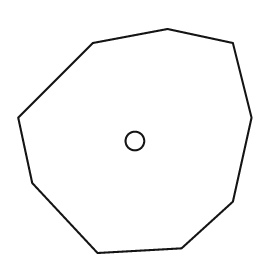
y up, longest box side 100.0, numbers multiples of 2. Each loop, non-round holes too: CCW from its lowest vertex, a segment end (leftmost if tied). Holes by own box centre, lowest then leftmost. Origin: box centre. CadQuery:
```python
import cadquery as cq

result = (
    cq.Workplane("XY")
    .moveTo(-16.0, -48.0)
    .lineTo(20.0, -46.0)
    .lineTo(42.0, -26.0)
    .lineTo(50.0, 10.0)
    .lineTo(42.0, 42.0)
    .lineTo(14.0, 48.0)
    .lineTo(-18.0, 42.0)
    .lineTo(-50.0, 10.0)
    .lineTo(-44.0, -18.0)
    .close()
    .moveTo(0.0, 0.0)
    .circle(4.0)
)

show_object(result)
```